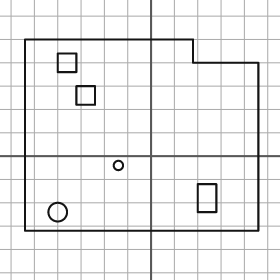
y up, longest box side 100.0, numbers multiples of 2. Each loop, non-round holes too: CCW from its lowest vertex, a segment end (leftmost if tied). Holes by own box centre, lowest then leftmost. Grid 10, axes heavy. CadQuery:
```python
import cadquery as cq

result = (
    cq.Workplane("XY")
    .moveTo(-54.0, -32.0)
    .lineTo(46.0, -32.0)
    .lineTo(46.0, 40.0)
    .lineTo(18.0, 40.0)
    .lineTo(18.0, 50.0)
    .lineTo(-54.0, 50.0)
    .close()
    .moveTo(-40.0, -24.0)
    .circle(4.0)
    .moveTo(20.0, -24.0)
    .lineTo(28.0, -24.0)
    .lineTo(28.0, -12.0)
    .lineTo(20.0, -12.0)
    .close()
    .moveTo(-14.0, -4.0)
    .circle(2.0)
    .moveTo(-32.0, 22.0)
    .lineTo(-24.0, 22.0)
    .lineTo(-24.0, 30.0)
    .lineTo(-32.0, 30.0)
    .close()
    .moveTo(-40.0, 36.0)
    .lineTo(-32.0, 36.0)
    .lineTo(-32.0, 44.0)
    .lineTo(-40.0, 44.0)
    .close()
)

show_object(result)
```